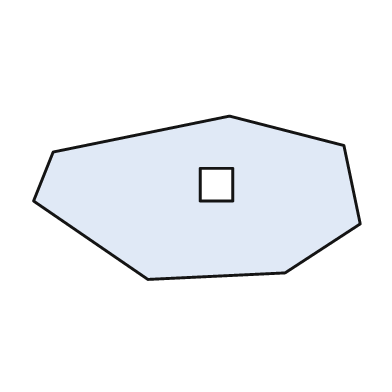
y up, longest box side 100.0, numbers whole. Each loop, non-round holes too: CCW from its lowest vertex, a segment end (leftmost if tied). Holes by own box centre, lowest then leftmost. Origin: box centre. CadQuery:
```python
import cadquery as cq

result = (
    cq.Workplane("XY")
    .moveTo(-15.0, -25.0)
    .lineTo(27.0, -23.0)
    .lineTo(50.0, -8.0)
    .lineTo(45.0, 16.0)
    .lineTo(10.0, 25.0)
    .lineTo(-44.0, 14.0)
    .lineTo(-50.0, -1.0)
    .close()
    .moveTo(1.0, -1.0)
    .lineTo(11.0, -1.0)
    .lineTo(11.0, 9.0)
    .lineTo(1.0, 9.0)
    .close()
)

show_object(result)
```